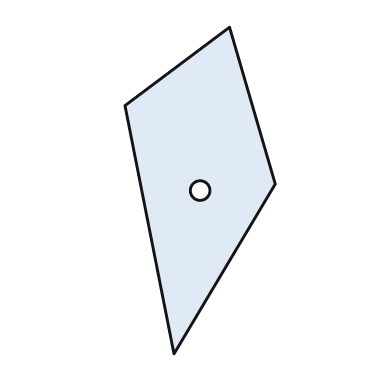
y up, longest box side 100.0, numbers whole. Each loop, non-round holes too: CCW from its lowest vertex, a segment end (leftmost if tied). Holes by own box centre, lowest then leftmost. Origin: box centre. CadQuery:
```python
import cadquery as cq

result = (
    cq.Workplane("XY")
    .moveTo(-8.0, -50.0)
    .lineTo(23.0, 2.0)
    .lineTo(9.0, 50.0)
    .lineTo(-23.0, 26.0)
    .close()
    .moveTo(0.0, 0.0)
    .circle(3.0)
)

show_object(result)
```